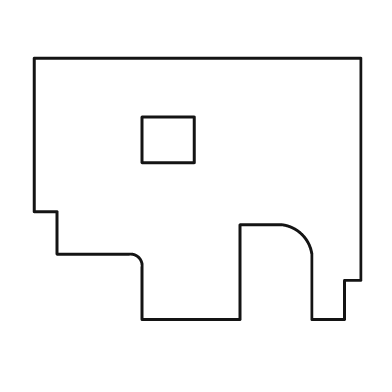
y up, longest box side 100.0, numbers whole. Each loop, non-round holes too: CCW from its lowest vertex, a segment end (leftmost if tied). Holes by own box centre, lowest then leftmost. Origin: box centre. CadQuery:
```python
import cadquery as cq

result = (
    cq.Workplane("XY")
    .moveTo(-17.0, -40.0)
    .lineTo(13.0, -40.0)
    .lineTo(13.0, -11.0)
    .lineTo(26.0, -11.0)
    .threePointArc((32.0, -14.0), (35.0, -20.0))
    .lineTo(35.0, -40.0)
    .lineTo(45.0, -40.0)
    .lineTo(45.0, -28.0)
    .lineTo(50.0, -28.0)
    .lineTo(50.0, 40.0)
    .lineTo(-50.0, 40.0)
    .lineTo(-50.0, -7.0)
    .lineTo(-43.0, -7.0)
    .lineTo(-43.0, -20.0)
    .lineTo(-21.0, -20.0)
    .threePointArc((-18.0, -21.0), (-17.0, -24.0))
    .close()
    .moveTo(-17.0, 8.0)
    .lineTo(-1.0, 8.0)
    .lineTo(-1.0, 22.0)
    .lineTo(-17.0, 22.0)
    .close()
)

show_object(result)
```